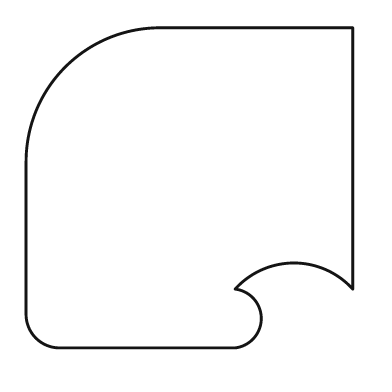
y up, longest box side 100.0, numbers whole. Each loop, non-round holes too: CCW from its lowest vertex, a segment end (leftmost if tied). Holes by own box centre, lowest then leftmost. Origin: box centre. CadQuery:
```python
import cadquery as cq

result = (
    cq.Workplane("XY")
    .moveTo(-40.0, -49.0)
    .lineTo(14.0, -49.0)
    .threePointArc((22.0, -40.0), (14.0, -31.0))
    .threePointArc((32.0, -23.0), (50.0, -31.0))
    .lineTo(50.0, 49.0)
    .lineTo(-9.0, 49.0)
    .threePointArc((-38.0, 37.0), (-50.0, 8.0))
    .lineTo(-50.0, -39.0)
    .threePointArc((-47.0, -46.0), (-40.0, -49.0))
    .close()
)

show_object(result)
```